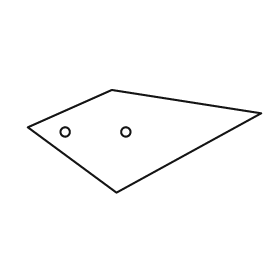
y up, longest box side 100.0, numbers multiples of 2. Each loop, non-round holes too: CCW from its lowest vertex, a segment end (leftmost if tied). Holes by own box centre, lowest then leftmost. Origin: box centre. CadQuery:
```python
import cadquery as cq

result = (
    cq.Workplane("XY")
    .moveTo(-12.0, -22.0)
    .lineTo(50.0, 12.0)
    .lineTo(-14.0, 22.0)
    .lineTo(-50.0, 6.0)
    .close()
    .moveTo(-34.0, 4.0)
    .circle(2.0)
    .moveTo(-8.0, 4.0)
    .circle(2.0)
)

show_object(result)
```